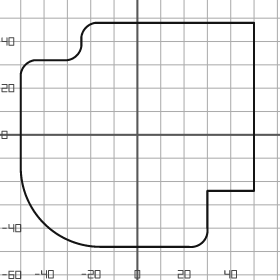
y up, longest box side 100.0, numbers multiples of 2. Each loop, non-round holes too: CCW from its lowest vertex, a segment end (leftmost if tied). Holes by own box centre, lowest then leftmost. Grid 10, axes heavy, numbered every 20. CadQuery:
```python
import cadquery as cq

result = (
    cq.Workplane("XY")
    .moveTo(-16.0, -48.0)
    .lineTo(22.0, -48.0)
    .threePointArc((28.0, -46.0), (30.0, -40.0))
    .lineTo(30.0, -24.0)
    .lineTo(50.0, -24.0)
    .lineTo(50.0, 48.0)
    .lineTo(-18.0, 48.0)
    .threePointArc((-22.0, 46.0), (-24.0, 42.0))
    .lineTo(-24.0, 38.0)
    .threePointArc((-26.0, 34.0), (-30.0, 32.0))
    .lineTo(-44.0, 32.0)
    .threePointArc((-48.0, 30.0), (-50.0, 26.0))
    .lineTo(-50.0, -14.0)
    .threePointArc((-40.0, -38.0), (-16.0, -48.0))
    .close()
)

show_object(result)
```